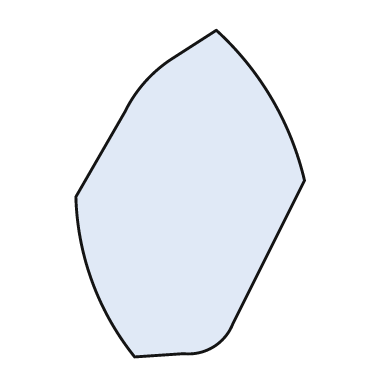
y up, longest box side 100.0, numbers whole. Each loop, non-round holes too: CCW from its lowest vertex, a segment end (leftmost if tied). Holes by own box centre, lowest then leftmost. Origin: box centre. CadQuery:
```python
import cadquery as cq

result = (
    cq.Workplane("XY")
    .moveTo(-17.0, -50.0)
    .lineTo(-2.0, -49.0)
    .threePointArc((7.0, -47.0), (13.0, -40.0))
    .lineTo(35.0, 4.0)
    .threePointArc((25.0, 29.0), (8.0, 50.0))
    .lineTo(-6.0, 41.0)
    .threePointArc((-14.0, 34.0), (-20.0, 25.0))
    .lineTo(-35.0, -1.0)
    .threePointArc((-30.0, -27.0), (-17.0, -50.0))
    .close()
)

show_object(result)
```